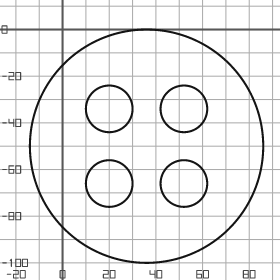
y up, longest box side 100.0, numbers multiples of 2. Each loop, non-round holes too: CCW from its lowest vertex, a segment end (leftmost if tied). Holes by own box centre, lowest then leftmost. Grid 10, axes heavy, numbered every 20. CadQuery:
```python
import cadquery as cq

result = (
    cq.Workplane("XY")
    .moveTo(36.0, -50.0)
    .circle(50.0)
    .moveTo(20.0, -66.0)
    .circle(10.0)
    .moveTo(52.0, -66.0)
    .circle(10.0)
    .moveTo(20.0, -34.0)
    .circle(10.0)
    .moveTo(52.0, -34.0)
    .circle(10.0)
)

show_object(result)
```